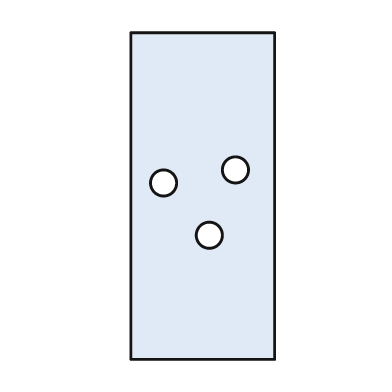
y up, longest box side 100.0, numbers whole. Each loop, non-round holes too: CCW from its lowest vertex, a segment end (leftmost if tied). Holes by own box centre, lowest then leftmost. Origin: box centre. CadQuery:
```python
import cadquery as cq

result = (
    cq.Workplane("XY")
    .moveTo(-22.0, -50.0)
    .lineTo(22.0, -50.0)
    .lineTo(22.0, 50.0)
    .lineTo(-22.0, 50.0)
    .close()
    .moveTo(2.0, -12.0)
    .circle(4.0)
    .moveTo(-12.0, 4.0)
    .circle(4.0)
    .moveTo(10.0, 8.0)
    .circle(4.0)
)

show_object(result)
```